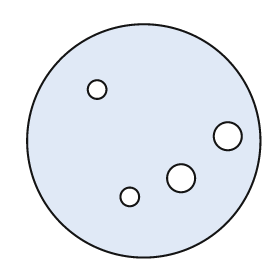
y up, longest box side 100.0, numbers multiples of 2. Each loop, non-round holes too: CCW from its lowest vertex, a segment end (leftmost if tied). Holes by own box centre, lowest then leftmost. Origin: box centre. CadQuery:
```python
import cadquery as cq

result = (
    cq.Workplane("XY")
    .moveTo(0.0, 0.0)
    .circle(50.0)
    .moveTo(-6.0, -24.0)
    .circle(4.0)
    .moveTo(16.0, -16.0)
    .circle(6.0)
    .moveTo(36.0, 2.0)
    .circle(6.0)
    .moveTo(-20.0, 22.0)
    .circle(4.0)
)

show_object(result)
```